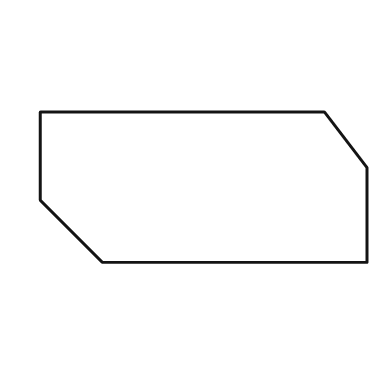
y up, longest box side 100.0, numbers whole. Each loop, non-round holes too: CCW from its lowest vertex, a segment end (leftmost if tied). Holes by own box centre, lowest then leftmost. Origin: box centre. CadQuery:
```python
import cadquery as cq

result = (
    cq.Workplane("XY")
    .moveTo(-31.0, -23.0)
    .lineTo(50.0, -23.0)
    .lineTo(50.0, 6.0)
    .lineTo(37.0, 23.0)
    .lineTo(-50.0, 23.0)
    .lineTo(-50.0, -4.0)
    .close()
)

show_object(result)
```